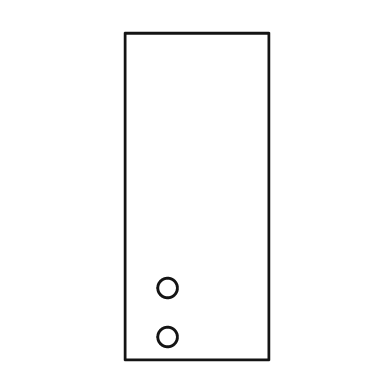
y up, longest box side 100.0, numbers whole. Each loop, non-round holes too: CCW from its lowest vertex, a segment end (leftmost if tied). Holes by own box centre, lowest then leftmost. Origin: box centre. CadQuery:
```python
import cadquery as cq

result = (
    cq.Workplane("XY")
    .moveTo(-22.0, -50.0)
    .lineTo(22.0, -50.0)
    .lineTo(22.0, 50.0)
    .lineTo(-22.0, 50.0)
    .close()
    .moveTo(-9.0, -43.0)
    .circle(3.0)
    .moveTo(-9.0, -28.0)
    .circle(3.0)
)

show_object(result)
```